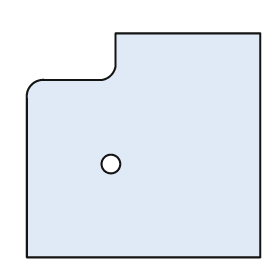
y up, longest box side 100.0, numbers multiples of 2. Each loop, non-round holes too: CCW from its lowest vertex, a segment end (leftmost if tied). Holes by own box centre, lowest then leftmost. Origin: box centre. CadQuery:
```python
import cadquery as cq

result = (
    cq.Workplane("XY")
    .moveTo(-50.0, -48.0)
    .lineTo(50.0, -48.0)
    .lineTo(50.0, 48.0)
    .lineTo(-12.0, 48.0)
    .lineTo(-12.0, 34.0)
    .threePointArc((-14.0, 30.0), (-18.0, 28.0))
    .lineTo(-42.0, 28.0)
    .threePointArc((-48.0, 26.0), (-50.0, 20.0))
    .close()
    .moveTo(-14.0, -8.0)
    .circle(4.0)
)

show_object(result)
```